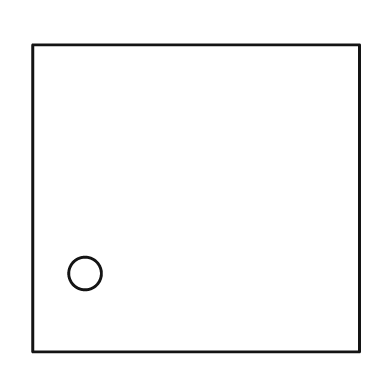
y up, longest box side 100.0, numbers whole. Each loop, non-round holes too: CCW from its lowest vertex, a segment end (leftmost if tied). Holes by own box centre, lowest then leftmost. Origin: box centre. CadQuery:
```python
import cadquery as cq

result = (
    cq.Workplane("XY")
    .moveTo(-50.0, -47.0)
    .lineTo(50.0, -47.0)
    .lineTo(50.0, 47.0)
    .lineTo(-50.0, 47.0)
    .close()
    .moveTo(-34.0, -23.0)
    .circle(5.0)
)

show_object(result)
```